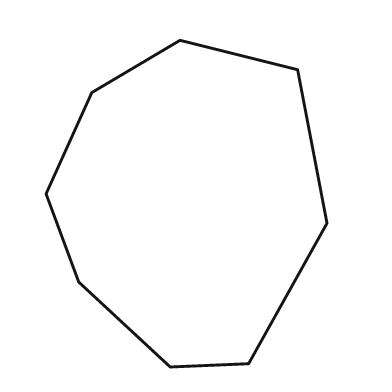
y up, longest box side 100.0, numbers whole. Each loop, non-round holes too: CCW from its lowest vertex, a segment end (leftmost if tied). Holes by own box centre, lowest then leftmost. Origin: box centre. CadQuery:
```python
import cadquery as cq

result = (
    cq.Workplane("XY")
    .moveTo(-5.0, -50.0)
    .lineTo(19.0, -49.0)
    .lineTo(43.0, -6.0)
    .lineTo(34.0, 41.0)
    .lineTo(-2.0, 50.0)
    .lineTo(-29.0, 34.0)
    .lineTo(-43.0, 3.0)
    .lineTo(-33.0, -24.0)
    .close()
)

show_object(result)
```